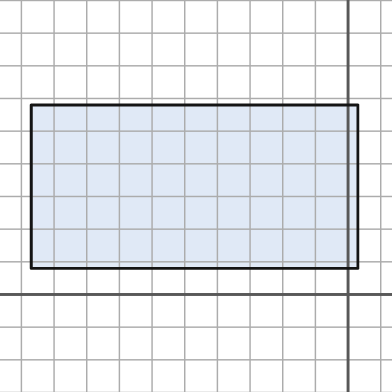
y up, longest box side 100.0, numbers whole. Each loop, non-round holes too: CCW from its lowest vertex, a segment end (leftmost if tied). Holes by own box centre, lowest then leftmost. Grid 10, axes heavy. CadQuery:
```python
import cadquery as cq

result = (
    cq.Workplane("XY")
    .moveTo(-97.0, 8.0)
    .lineTo(3.0, 8.0)
    .lineTo(3.0, 58.0)
    .lineTo(-97.0, 58.0)
    .close()
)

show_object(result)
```